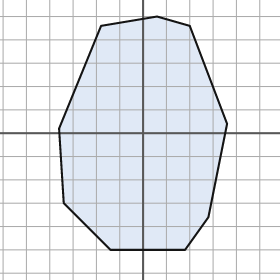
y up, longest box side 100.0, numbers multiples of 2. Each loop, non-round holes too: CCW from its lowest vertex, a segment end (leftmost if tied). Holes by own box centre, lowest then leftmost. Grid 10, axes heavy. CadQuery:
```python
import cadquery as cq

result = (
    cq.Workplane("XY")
    .moveTo(-14.0, -50.0)
    .lineTo(18.0, -50.0)
    .lineTo(28.0, -36.0)
    .lineTo(36.0, 4.0)
    .lineTo(20.0, 46.0)
    .lineTo(6.0, 50.0)
    .lineTo(-18.0, 46.0)
    .lineTo(-36.0, 2.0)
    .lineTo(-34.0, -30.0)
    .close()
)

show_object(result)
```